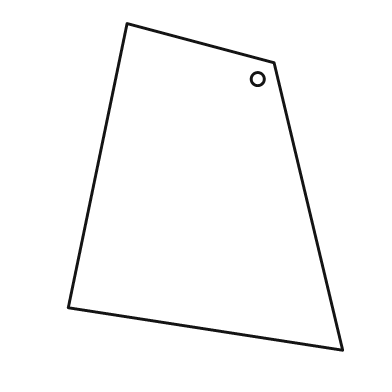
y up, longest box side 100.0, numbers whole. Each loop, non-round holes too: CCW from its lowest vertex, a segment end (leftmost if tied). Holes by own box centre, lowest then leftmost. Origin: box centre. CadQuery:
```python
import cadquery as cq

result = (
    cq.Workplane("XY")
    .moveTo(42.0, -50.0)
    .lineTo(21.0, 38.0)
    .lineTo(-24.0, 50.0)
    .lineTo(-42.0, -37.0)
    .close()
    .moveTo(16.0, 33.0)
    .circle(2.0)
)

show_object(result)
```